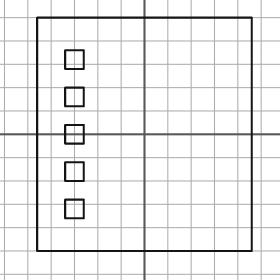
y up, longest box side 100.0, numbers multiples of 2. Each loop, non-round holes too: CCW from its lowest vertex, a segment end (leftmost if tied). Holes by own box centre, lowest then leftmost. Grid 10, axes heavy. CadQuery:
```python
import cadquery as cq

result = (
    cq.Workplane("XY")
    .moveTo(-46.0, -50.0)
    .lineTo(46.0, -50.0)
    .lineTo(46.0, 50.0)
    .lineTo(-46.0, 50.0)
    .close()
    .moveTo(-34.0, -36.0)
    .lineTo(-26.0, -36.0)
    .lineTo(-26.0, -28.0)
    .lineTo(-34.0, -28.0)
    .close()
    .moveTo(-34.0, -20.0)
    .lineTo(-26.0, -20.0)
    .lineTo(-26.0, -12.0)
    .lineTo(-34.0, -12.0)
    .close()
    .moveTo(-34.0, -4.0)
    .lineTo(-26.0, -4.0)
    .lineTo(-26.0, 4.0)
    .lineTo(-34.0, 4.0)
    .close()
    .moveTo(-34.0, 12.0)
    .lineTo(-26.0, 12.0)
    .lineTo(-26.0, 20.0)
    .lineTo(-34.0, 20.0)
    .close()
    .moveTo(-34.0, 28.0)
    .lineTo(-26.0, 28.0)
    .lineTo(-26.0, 36.0)
    .lineTo(-34.0, 36.0)
    .close()
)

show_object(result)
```